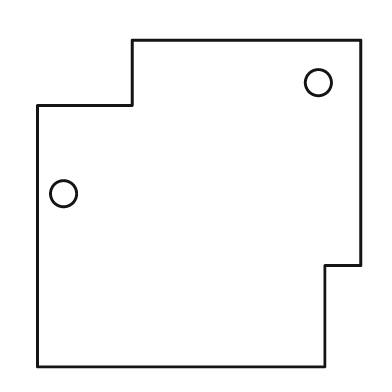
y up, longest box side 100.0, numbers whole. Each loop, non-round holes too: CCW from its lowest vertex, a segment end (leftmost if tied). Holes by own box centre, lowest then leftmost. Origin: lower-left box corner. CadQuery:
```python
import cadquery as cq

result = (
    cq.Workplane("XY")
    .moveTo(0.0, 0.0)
    .lineTo(88.0, 0.0)
    .lineTo(88.0, 31.0)
    .lineTo(99.0, 31.0)
    .lineTo(99.0, 100.0)
    .lineTo(29.0, 100.0)
    .lineTo(29.0, 80.0)
    .lineTo(0.0, 80.0)
    .close()
    .moveTo(8.0, 53.0)
    .circle(4.0)
    .moveTo(86.0, 87.0)
    .circle(4.0)
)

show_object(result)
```